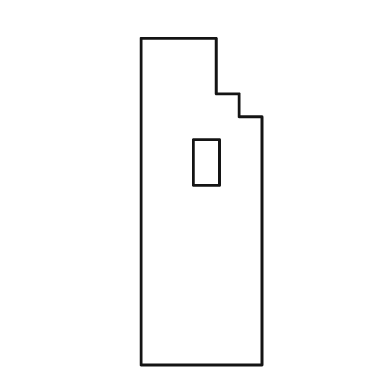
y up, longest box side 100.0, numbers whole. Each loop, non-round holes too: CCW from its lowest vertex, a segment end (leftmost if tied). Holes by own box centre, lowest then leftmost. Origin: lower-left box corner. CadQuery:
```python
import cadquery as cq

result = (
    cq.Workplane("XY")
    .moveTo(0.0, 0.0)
    .lineTo(37.0, 0.0)
    .lineTo(37.0, 76.0)
    .lineTo(30.0, 76.0)
    .lineTo(30.0, 83.0)
    .lineTo(23.0, 83.0)
    .lineTo(23.0, 100.0)
    .lineTo(0.0, 100.0)
    .close()
    .moveTo(16.0, 55.0)
    .lineTo(24.0, 55.0)
    .lineTo(24.0, 69.0)
    .lineTo(16.0, 69.0)
    .close()
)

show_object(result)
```